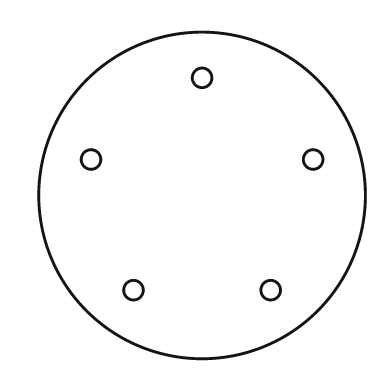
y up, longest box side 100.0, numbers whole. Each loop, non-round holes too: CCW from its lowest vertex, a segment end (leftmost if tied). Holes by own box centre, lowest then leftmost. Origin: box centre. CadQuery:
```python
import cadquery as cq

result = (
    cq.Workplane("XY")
    .moveTo(0.0, 0.0)
    .circle(50.0)
    .moveTo(-21.0, -29.0)
    .circle(3.0)
    .moveTo(21.0, -29.0)
    .circle(3.0)
    .moveTo(-34.0, 11.0)
    .circle(3.0)
    .moveTo(34.0, 11.0)
    .circle(3.0)
    .moveTo(0.0, 36.0)
    .circle(3.0)
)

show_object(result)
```